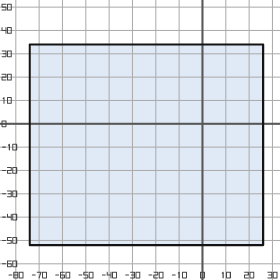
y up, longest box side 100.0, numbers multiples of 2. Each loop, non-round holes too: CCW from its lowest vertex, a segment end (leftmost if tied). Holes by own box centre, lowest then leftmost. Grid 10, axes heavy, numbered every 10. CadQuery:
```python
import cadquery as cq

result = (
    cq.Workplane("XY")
    .moveTo(-74.0, -52.0)
    .lineTo(26.0, -52.0)
    .lineTo(26.0, 34.0)
    .lineTo(-74.0, 34.0)
    .close()
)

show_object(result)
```